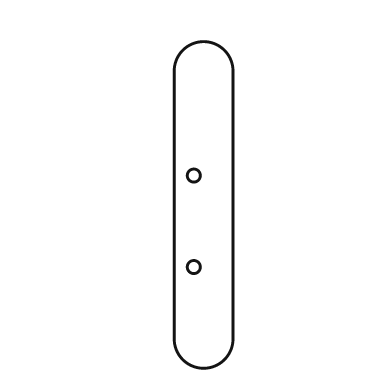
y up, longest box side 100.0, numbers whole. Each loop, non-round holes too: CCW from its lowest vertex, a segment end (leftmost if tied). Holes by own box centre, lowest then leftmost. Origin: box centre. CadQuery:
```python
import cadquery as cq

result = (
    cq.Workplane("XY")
    .moveTo(-9.0, -41.0)
    .threePointArc((0.0, -50.0), (9.0, -41.0))
    .lineTo(9.0, 41.0)
    .threePointArc((0.0, 50.0), (-9.0, 41.0))
    .close()
    .moveTo(-3.0, -19.0)
    .circle(2.0)
    .moveTo(-3.0, 9.0)
    .circle(2.0)
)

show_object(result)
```